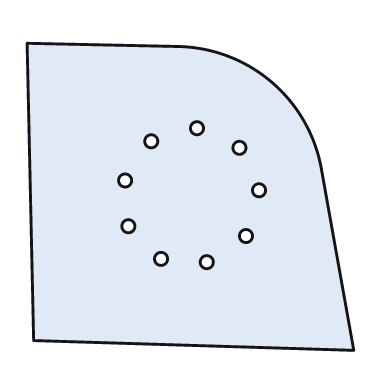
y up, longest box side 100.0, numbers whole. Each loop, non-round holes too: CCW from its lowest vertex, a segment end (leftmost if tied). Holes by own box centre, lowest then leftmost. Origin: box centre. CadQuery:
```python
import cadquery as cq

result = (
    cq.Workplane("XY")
    .moveTo(50.0, -47.0)
    .lineTo(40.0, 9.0)
    .threePointArc((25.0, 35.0), (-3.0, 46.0))
    .lineTo(-50.0, 47.0)
    .lineTo(-48.0, -44.0)
    .close()
    .moveTo(5.0, -20.0)
    .circle(2.0)
    .moveTo(-9.0, -19.0)
    .circle(2.0)
    .moveTo(17.0, -12.0)
    .circle(2.0)
    .moveTo(-19.0, -9.0)
    .circle(2.0)
    .moveTo(21.0, 2.0)
    .circle(2.0)
    .moveTo(-20.0, 5.0)
    .circle(2.0)
    .moveTo(15.0, 15.0)
    .circle(2.0)
    .moveTo(-12.0, 17.0)
    .circle(2.0)
    .moveTo(2.0, 21.0)
    .circle(2.0)
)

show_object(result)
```